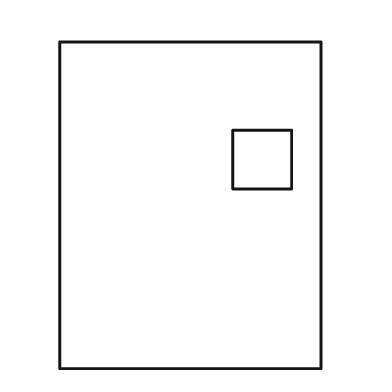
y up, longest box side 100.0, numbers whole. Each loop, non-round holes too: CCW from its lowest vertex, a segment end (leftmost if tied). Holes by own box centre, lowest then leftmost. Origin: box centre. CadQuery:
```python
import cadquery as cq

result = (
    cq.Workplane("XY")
    .moveTo(-40.0, -50.0)
    .lineTo(40.0, -50.0)
    .lineTo(40.0, 50.0)
    .lineTo(-40.0, 50.0)
    .close()
    .moveTo(13.0, 5.0)
    .lineTo(31.0, 5.0)
    .lineTo(31.0, 23.0)
    .lineTo(13.0, 23.0)
    .close()
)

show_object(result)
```